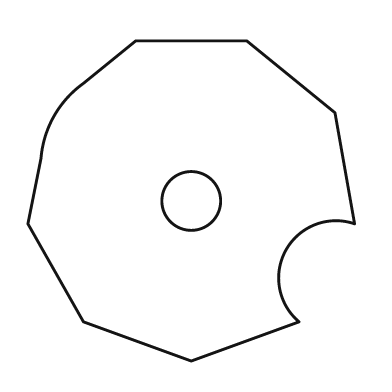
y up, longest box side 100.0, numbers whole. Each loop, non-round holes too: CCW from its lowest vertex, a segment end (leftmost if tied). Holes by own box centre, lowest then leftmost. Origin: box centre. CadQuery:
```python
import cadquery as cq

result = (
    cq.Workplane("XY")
    .moveTo(0.0, -49.0)
    .lineTo(33.0, -37.0)
    .threePointArc((29.0, -15.0), (50.0, -7.0))
    .lineTo(44.0, 27.0)
    .lineTo(17.0, 49.0)
    .lineTo(-17.0, 49.0)
    .lineTo(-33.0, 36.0)
    .threePointArc((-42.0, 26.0), (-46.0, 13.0))
    .lineTo(-50.0, -7.0)
    .lineTo(-33.0, -37.0)
    .close()
    .moveTo(0.0, 0.0)
    .circle(9.0)
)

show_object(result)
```